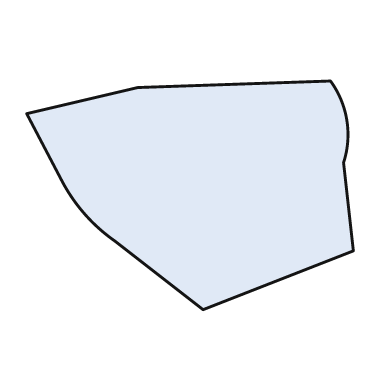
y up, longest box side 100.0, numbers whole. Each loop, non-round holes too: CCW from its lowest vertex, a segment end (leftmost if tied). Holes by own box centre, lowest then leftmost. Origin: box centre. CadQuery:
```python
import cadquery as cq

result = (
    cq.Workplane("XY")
    .moveTo(4.0, -35.0)
    .lineTo(50.0, -17.0)
    .lineTo(47.0, 10.0)
    .threePointArc((48.0, 23.0), (43.0, 35.0))
    .lineTo(-16.0, 33.0)
    .lineTo(-50.0, 25.0)
    .lineTo(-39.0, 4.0)
    .threePointArc((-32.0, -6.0), (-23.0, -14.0))
    .close()
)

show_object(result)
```